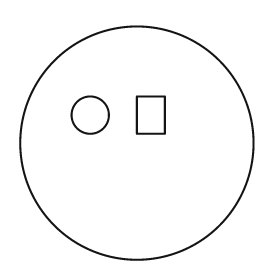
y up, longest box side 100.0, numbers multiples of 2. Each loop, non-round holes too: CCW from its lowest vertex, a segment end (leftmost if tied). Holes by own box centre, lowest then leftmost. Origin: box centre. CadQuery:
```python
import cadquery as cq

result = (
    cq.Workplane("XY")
    .moveTo(0.0, 0.0)
    .circle(50.0)
    .moveTo(-20.0, 12.0)
    .circle(8.0)
    .moveTo(0.0, 4.0)
    .lineTo(12.0, 4.0)
    .lineTo(12.0, 20.0)
    .lineTo(0.0, 20.0)
    .close()
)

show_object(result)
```